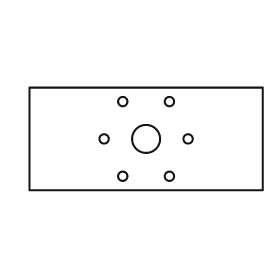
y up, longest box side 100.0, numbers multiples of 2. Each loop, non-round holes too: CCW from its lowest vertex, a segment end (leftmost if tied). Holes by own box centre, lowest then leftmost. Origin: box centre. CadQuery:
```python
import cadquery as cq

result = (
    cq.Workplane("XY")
    .moveTo(-50.0, -22.0)
    .lineTo(50.0, -22.0)
    .lineTo(50.0, 22.0)
    .lineTo(-50.0, 22.0)
    .close()
    .moveTo(-10.0, -16.0)
    .circle(2.0)
    .moveTo(10.0, -16.0)
    .circle(2.0)
    .moveTo(-18.0, 0.0)
    .circle(2.0)
    .moveTo(0.0, 0.0)
    .circle(6.0)
    .moveTo(18.0, 0.0)
    .circle(2.0)
    .moveTo(-10.0, 16.0)
    .circle(2.0)
    .moveTo(10.0, 16.0)
    .circle(2.0)
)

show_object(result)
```